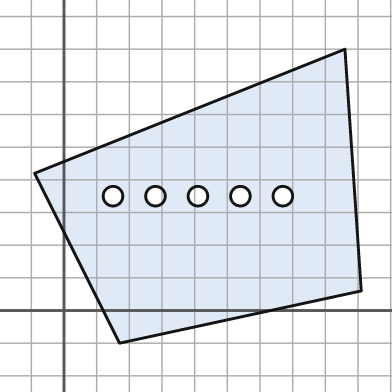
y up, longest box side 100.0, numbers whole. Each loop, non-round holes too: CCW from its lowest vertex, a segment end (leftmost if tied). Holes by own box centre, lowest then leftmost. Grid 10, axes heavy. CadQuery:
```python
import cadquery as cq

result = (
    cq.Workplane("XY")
    .moveTo(17.0, -10.0)
    .lineTo(91.0, 6.0)
    .lineTo(86.0, 80.0)
    .lineTo(-9.0, 42.0)
    .close()
    .moveTo(15.0, 35.0)
    .circle(3.0)
    .moveTo(28.0, 35.0)
    .circle(3.0)
    .moveTo(41.0, 35.0)
    .circle(3.0)
    .moveTo(54.0, 35.0)
    .circle(3.0)
    .moveTo(67.0, 35.0)
    .circle(3.0)
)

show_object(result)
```